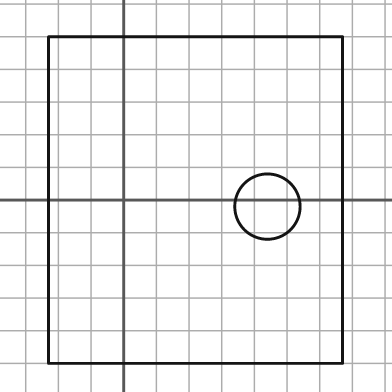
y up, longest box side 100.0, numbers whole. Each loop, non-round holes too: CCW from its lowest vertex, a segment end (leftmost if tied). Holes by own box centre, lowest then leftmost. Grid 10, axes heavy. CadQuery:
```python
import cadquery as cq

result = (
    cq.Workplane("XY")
    .moveTo(-23.0, -50.0)
    .lineTo(67.0, -50.0)
    .lineTo(67.0, 50.0)
    .lineTo(-23.0, 50.0)
    .close()
    .moveTo(44.0, -2.0)
    .circle(10.0)
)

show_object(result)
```